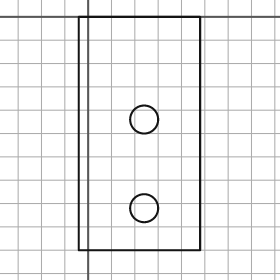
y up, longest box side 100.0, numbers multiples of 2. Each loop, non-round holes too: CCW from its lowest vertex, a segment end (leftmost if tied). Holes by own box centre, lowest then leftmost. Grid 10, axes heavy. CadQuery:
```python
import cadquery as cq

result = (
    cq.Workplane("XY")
    .moveTo(-4.0, -100.0)
    .lineTo(48.0, -100.0)
    .lineTo(48.0, 0.0)
    .lineTo(-4.0, 0.0)
    .close()
    .moveTo(24.0, -82.0)
    .circle(6.0)
    .moveTo(24.0, -44.0)
    .circle(6.0)
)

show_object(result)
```